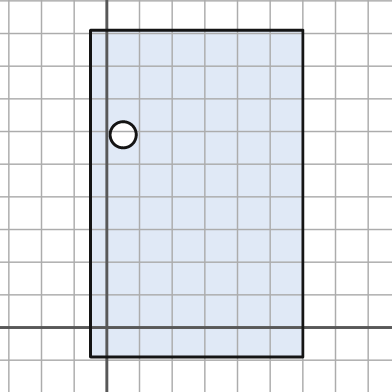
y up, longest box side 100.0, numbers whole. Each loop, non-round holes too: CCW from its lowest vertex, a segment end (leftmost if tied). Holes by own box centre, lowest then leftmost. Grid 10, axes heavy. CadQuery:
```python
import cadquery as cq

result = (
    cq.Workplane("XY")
    .moveTo(-5.0, -9.0)
    .lineTo(60.0, -9.0)
    .lineTo(60.0, 91.0)
    .lineTo(-5.0, 91.0)
    .close()
    .moveTo(5.0, 59.0)
    .circle(4.0)
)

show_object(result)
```